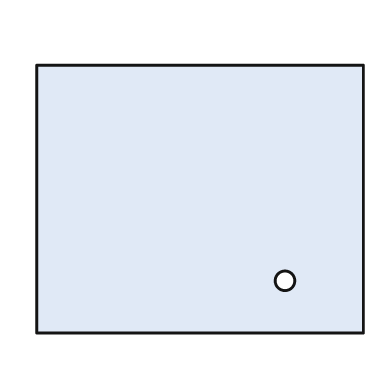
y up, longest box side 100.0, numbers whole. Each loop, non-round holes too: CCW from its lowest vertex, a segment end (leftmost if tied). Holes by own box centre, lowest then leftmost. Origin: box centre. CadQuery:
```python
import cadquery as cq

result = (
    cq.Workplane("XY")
    .moveTo(-50.0, -41.0)
    .lineTo(50.0, -41.0)
    .lineTo(50.0, 41.0)
    .lineTo(-50.0, 41.0)
    .close()
    .moveTo(26.0, -25.0)
    .circle(3.0)
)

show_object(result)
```